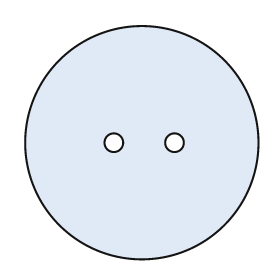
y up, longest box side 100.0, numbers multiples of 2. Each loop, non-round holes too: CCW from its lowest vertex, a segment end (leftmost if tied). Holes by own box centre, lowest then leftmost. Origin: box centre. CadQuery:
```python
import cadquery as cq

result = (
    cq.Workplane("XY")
    .moveTo(0.0, 0.0)
    .circle(50.0)
    .moveTo(-12.0, 0.0)
    .circle(4.0)
    .moveTo(14.0, 0.0)
    .circle(4.0)
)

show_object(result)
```